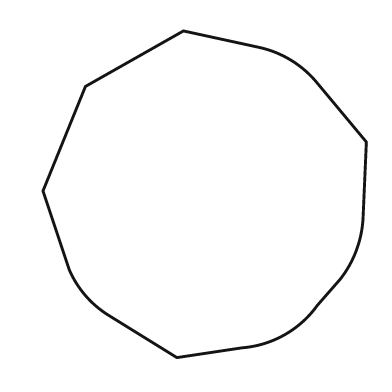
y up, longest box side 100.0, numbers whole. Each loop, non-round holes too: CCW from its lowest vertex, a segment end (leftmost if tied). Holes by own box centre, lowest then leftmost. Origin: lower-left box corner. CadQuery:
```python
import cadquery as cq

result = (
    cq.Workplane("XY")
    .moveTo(41.0, 0.0)
    .lineTo(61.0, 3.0)
    .threePointArc((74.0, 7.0), (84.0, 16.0))
    .lineTo(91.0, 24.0)
    .threePointArc((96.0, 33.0), (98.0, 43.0))
    .lineTo(99.0, 66.0)
    .lineTo(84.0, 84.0)
    .threePointArc((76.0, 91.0), (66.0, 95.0))
    .lineTo(43.0, 100.0)
    .lineTo(13.0, 83.0)
    .lineTo(0.0, 51.0)
    .lineTo(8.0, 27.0)
    .threePointArc((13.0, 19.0), (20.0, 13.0))
    .close()
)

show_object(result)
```